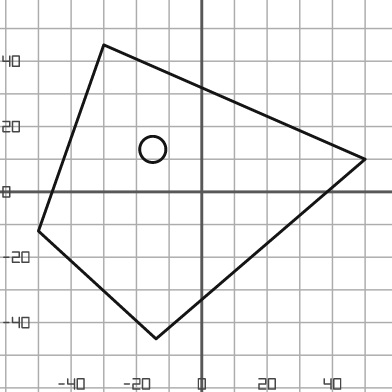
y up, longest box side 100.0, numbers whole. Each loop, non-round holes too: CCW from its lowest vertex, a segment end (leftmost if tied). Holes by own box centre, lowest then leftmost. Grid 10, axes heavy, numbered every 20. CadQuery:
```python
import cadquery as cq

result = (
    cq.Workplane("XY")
    .moveTo(-14.0, -45.0)
    .lineTo(50.0, 10.0)
    .lineTo(-30.0, 45.0)
    .lineTo(-50.0, -12.0)
    .close()
    .moveTo(-15.0, 13.0)
    .circle(4.0)
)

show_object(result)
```